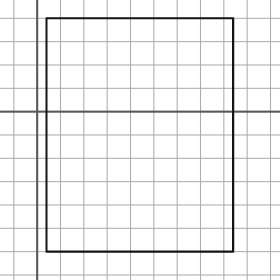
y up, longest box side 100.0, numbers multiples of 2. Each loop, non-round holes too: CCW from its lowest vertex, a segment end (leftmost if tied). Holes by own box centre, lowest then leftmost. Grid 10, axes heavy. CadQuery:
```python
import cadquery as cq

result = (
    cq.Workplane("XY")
    .moveTo(4.0, -60.0)
    .lineTo(84.0, -60.0)
    .lineTo(84.0, 40.0)
    .lineTo(4.0, 40.0)
    .close()
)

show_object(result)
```